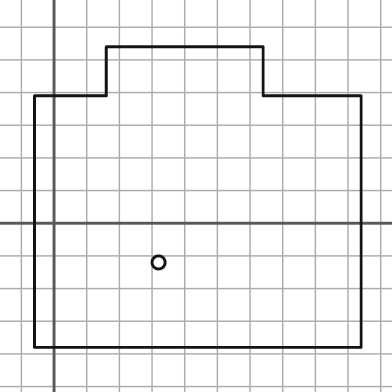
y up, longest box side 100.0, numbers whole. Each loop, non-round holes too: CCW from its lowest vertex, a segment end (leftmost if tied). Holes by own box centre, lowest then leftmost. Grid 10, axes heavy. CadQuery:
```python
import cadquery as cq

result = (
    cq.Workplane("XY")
    .moveTo(-6.0, -38.0)
    .lineTo(94.0, -38.0)
    .lineTo(94.0, 39.0)
    .lineTo(64.0, 39.0)
    .lineTo(64.0, 54.0)
    .lineTo(16.0, 54.0)
    .lineTo(16.0, 39.0)
    .lineTo(-6.0, 39.0)
    .close()
    .moveTo(32.0, -12.0)
    .circle(2.0)
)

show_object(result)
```